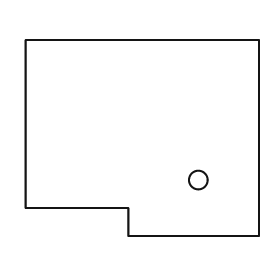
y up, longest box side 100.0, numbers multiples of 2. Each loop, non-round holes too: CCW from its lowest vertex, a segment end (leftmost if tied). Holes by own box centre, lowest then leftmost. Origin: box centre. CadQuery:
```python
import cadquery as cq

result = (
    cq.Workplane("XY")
    .moveTo(-6.0, -42.0)
    .lineTo(50.0, -42.0)
    .lineTo(50.0, 42.0)
    .lineTo(-50.0, 42.0)
    .lineTo(-50.0, -30.0)
    .lineTo(-6.0, -30.0)
    .close()
    .moveTo(24.0, -18.0)
    .circle(4.0)
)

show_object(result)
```